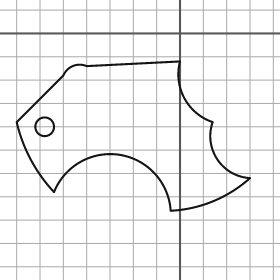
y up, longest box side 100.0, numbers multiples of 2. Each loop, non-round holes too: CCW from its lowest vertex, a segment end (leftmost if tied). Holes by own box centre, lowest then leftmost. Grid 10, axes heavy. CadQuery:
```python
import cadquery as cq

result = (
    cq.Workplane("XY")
    .moveTo(-4.0, -76.0)
    .threePointArc((14.0, -72.0), (30.0, -62.0))
    .threePointArc((16.0, -54.0), (14.0, -38.0))
    .threePointArc((2.0, -28.0), (0.0, -12.0))
    .lineTo(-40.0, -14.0)
    .threePointArc((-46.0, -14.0), (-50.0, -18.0))
    .lineTo(-70.0, -38.0)
    .threePointArc((-64.0, -54.0), (-54.0, -68.0))
    .threePointArc((-26.0, -52.0), (-4.0, -76.0))
    .close()
    .moveTo(-58.0, -40.0)
    .circle(4.0)
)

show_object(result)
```